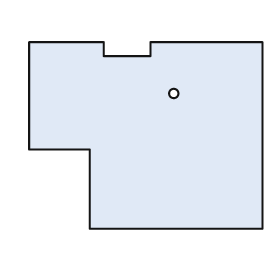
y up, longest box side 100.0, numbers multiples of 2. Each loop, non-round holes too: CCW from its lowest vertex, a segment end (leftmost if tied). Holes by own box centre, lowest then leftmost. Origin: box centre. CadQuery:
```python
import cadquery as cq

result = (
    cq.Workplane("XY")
    .moveTo(-24.0, -40.0)
    .lineTo(50.0, -40.0)
    .lineTo(50.0, 40.0)
    .lineTo(2.0, 40.0)
    .lineTo(2.0, 34.0)
    .lineTo(-18.0, 34.0)
    .lineTo(-18.0, 40.0)
    .lineTo(-50.0, 40.0)
    .lineTo(-50.0, -6.0)
    .lineTo(-24.0, -6.0)
    .close()
    .moveTo(12.0, 18.0)
    .circle(2.0)
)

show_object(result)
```